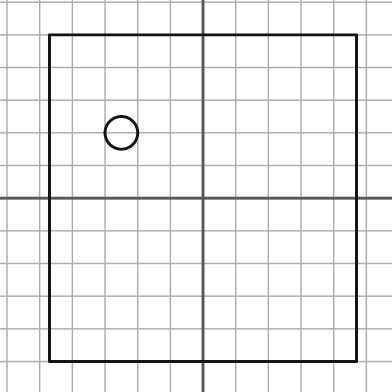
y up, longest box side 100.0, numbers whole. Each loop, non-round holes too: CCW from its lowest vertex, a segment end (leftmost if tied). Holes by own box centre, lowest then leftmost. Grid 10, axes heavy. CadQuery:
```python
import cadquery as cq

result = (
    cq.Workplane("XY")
    .moveTo(-47.0, -50.0)
    .lineTo(47.0, -50.0)
    .lineTo(47.0, 50.0)
    .lineTo(-47.0, 50.0)
    .close()
    .moveTo(-25.0, 20.0)
    .circle(5.0)
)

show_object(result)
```